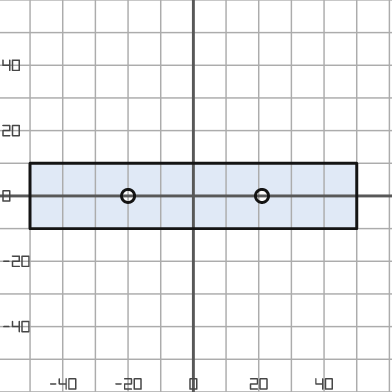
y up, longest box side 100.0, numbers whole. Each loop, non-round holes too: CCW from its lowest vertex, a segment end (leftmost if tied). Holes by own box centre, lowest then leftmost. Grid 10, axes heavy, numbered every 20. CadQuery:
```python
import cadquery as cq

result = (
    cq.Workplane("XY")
    .moveTo(-50.0, -10.0)
    .lineTo(50.0, -10.0)
    .lineTo(50.0, 10.0)
    .lineTo(-50.0, 10.0)
    .close()
    .moveTo(-20.0, 0.0)
    .circle(2.0)
    .moveTo(21.0, 0.0)
    .circle(2.0)
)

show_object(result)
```